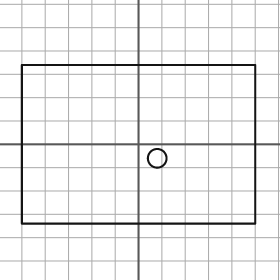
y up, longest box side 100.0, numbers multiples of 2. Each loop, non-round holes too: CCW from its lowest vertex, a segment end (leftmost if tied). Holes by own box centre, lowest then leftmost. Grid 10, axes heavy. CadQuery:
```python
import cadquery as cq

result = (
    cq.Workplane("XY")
    .moveTo(-50.0, -34.0)
    .lineTo(50.0, -34.0)
    .lineTo(50.0, 34.0)
    .lineTo(-50.0, 34.0)
    .close()
    .moveTo(8.0, -6.0)
    .circle(4.0)
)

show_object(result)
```